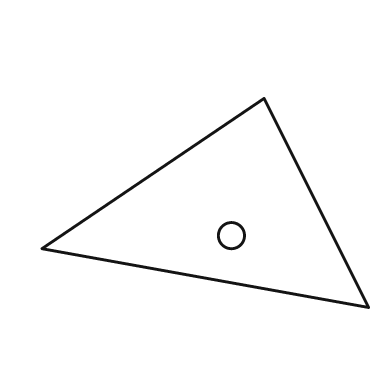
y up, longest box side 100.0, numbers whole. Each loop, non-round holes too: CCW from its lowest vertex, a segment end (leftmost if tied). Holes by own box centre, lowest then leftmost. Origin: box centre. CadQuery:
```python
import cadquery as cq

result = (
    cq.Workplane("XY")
    .moveTo(50.0, -32.0)
    .lineTo(18.0, 32.0)
    .lineTo(-50.0, -14.0)
    .close()
    .moveTo(8.0, -10.0)
    .circle(4.0)
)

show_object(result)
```